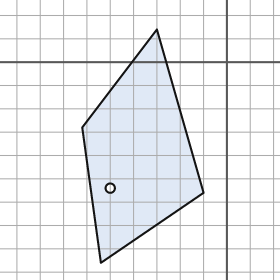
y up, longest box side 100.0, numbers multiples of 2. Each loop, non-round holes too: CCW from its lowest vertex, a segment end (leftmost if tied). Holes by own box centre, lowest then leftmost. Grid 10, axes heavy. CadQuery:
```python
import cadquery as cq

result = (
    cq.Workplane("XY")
    .moveTo(-54.0, -86.0)
    .lineTo(-10.0, -56.0)
    .lineTo(-30.0, 14.0)
    .lineTo(-62.0, -28.0)
    .close()
    .moveTo(-50.0, -54.0)
    .circle(2.0)
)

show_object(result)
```